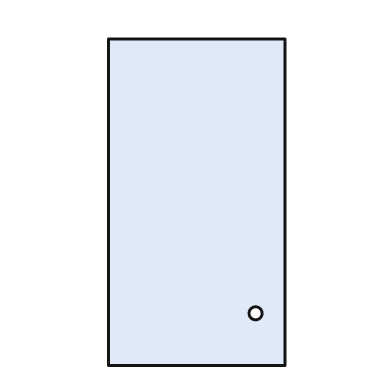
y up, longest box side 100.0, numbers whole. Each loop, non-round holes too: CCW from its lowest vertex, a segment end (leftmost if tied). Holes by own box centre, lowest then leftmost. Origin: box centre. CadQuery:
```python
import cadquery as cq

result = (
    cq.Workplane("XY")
    .moveTo(-27.0, -50.0)
    .lineTo(27.0, -50.0)
    .lineTo(27.0, 50.0)
    .lineTo(-27.0, 50.0)
    .close()
    .moveTo(18.0, -34.0)
    .circle(2.0)
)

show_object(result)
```